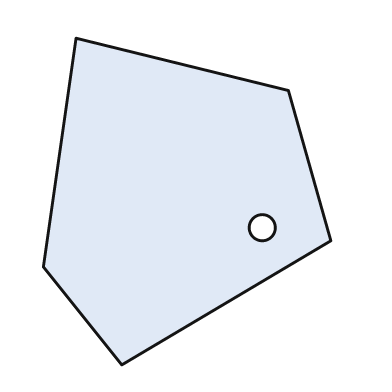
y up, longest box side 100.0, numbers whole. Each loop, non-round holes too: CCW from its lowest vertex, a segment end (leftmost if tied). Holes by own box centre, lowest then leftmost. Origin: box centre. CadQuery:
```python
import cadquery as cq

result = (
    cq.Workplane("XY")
    .moveTo(-20.0, -50.0)
    .lineTo(44.0, -12.0)
    .lineTo(31.0, 34.0)
    .lineTo(-34.0, 50.0)
    .lineTo(-44.0, -20.0)
    .close()
    .moveTo(23.0, -8.0)
    .circle(4.0)
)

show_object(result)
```